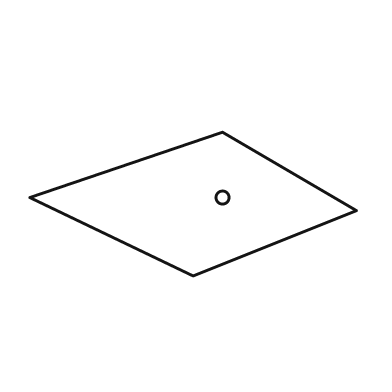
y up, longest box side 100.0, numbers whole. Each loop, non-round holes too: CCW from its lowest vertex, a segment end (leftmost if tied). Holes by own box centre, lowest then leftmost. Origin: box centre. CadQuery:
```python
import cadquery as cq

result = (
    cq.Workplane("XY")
    .moveTo(0.0, -22.0)
    .lineTo(50.0, -2.0)
    .lineTo(9.0, 22.0)
    .lineTo(-50.0, 2.0)
    .close()
    .moveTo(9.0, 2.0)
    .circle(2.0)
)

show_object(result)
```